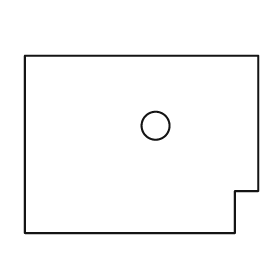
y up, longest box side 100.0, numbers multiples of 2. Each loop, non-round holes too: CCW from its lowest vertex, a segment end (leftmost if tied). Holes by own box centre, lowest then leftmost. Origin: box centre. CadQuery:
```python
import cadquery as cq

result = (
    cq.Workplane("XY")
    .moveTo(-50.0, -38.0)
    .lineTo(40.0, -38.0)
    .lineTo(40.0, -20.0)
    .lineTo(50.0, -20.0)
    .lineTo(50.0, 38.0)
    .lineTo(-50.0, 38.0)
    .close()
    .moveTo(6.0, 8.0)
    .circle(6.0)
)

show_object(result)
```